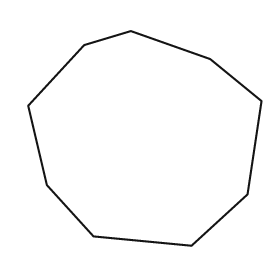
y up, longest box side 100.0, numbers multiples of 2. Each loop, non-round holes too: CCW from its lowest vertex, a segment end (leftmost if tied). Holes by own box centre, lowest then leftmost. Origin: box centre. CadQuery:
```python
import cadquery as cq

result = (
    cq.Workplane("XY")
    .moveTo(20.0, -46.0)
    .lineTo(44.0, -24.0)
    .lineTo(50.0, 16.0)
    .lineTo(28.0, 34.0)
    .lineTo(-6.0, 46.0)
    .lineTo(-26.0, 40.0)
    .lineTo(-50.0, 14.0)
    .lineTo(-42.0, -20.0)
    .lineTo(-22.0, -42.0)
    .close()
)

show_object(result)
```